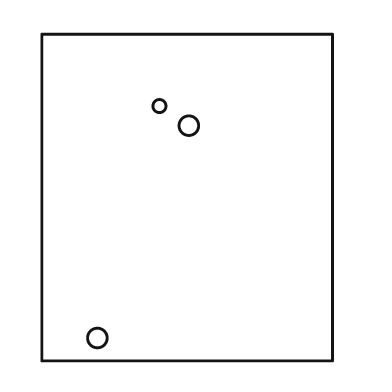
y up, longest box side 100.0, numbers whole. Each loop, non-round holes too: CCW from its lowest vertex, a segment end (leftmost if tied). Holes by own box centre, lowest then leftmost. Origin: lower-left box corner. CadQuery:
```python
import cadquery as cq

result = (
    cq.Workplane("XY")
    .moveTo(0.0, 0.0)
    .lineTo(89.0, 0.0)
    .lineTo(89.0, 100.0)
    .lineTo(0.0, 100.0)
    .close()
    .moveTo(17.0, 7.0)
    .circle(3.0)
    .moveTo(45.0, 72.0)
    .circle(3.0)
    .moveTo(36.0, 78.0)
    .circle(2.0)
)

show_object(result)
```